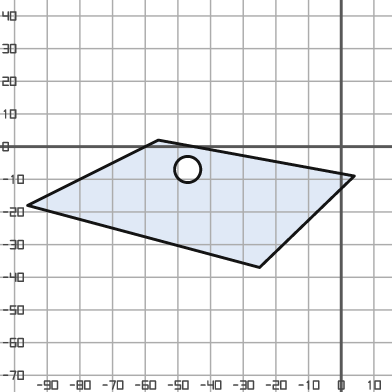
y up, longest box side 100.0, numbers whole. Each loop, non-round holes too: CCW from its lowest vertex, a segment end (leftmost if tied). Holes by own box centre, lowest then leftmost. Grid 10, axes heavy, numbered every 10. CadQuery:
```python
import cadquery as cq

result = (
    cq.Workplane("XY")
    .moveTo(-25.0, -37.0)
    .lineTo(4.0, -9.0)
    .lineTo(-56.0, 2.0)
    .lineTo(-96.0, -18.0)
    .close()
    .moveTo(-47.0, -7.0)
    .circle(4.0)
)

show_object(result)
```